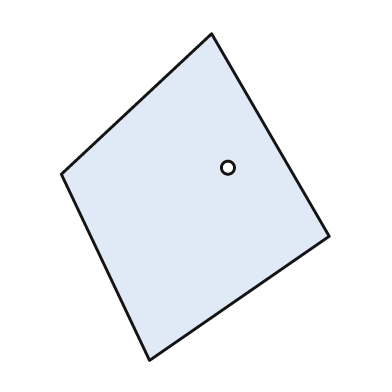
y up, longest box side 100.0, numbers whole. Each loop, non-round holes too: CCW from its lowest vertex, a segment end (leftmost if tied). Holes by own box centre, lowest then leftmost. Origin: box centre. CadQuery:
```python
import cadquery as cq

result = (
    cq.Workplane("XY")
    .moveTo(-14.0, -50.0)
    .lineTo(41.0, -12.0)
    .lineTo(5.0, 50.0)
    .lineTo(-41.0, 7.0)
    .close()
    .moveTo(10.0, 9.0)
    .circle(2.0)
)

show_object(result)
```